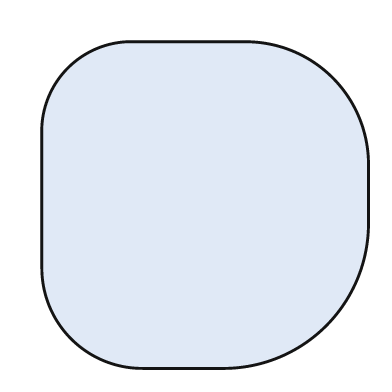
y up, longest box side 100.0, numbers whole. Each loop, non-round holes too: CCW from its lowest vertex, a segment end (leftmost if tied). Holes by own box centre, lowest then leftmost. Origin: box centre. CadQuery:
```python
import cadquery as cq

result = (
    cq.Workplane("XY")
    .moveTo(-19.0, -50.0)
    .lineTo(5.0, -50.0)
    .threePointArc((37.0, -37.0), (50.0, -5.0))
    .lineTo(50.0, 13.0)
    .threePointArc((39.0, 39.0), (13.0, 50.0))
    .lineTo(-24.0, 50.0)
    .threePointArc((-42.0, 42.0), (-50.0, 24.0))
    .lineTo(-50.0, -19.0)
    .threePointArc((-41.0, -41.0), (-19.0, -50.0))
    .close()
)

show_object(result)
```